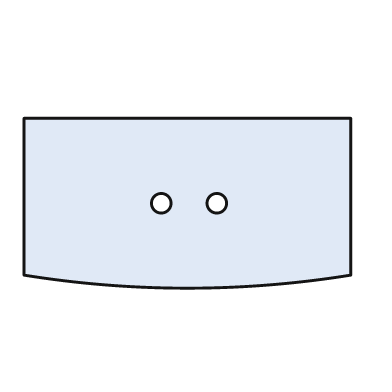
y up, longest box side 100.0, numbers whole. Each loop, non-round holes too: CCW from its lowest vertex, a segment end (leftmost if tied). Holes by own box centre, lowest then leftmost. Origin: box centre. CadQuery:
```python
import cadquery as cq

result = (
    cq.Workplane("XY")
    .moveTo(-50.0, -22.0)
    .threePointArc((0.0, -26.0), (50.0, -22.0))
    .lineTo(50.0, 26.0)
    .lineTo(-50.0, 26.0)
    .close()
    .moveTo(-8.0, 0.0)
    .circle(3.0)
    .moveTo(9.0, 0.0)
    .circle(3.0)
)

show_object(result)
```